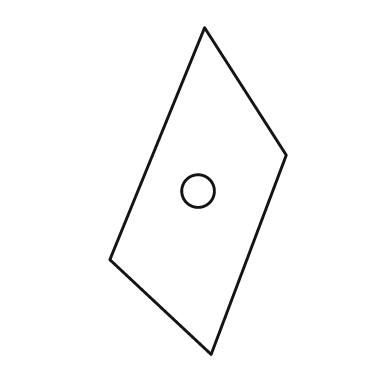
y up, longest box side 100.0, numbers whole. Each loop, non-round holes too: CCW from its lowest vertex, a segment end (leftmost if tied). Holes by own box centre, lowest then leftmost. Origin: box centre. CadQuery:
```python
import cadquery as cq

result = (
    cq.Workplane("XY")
    .moveTo(4.0, -50.0)
    .lineTo(27.0, 11.0)
    .lineTo(2.0, 50.0)
    .lineTo(-27.0, -21.0)
    .close()
    .moveTo(0.0, 0.0)
    .circle(5.0)
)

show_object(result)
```